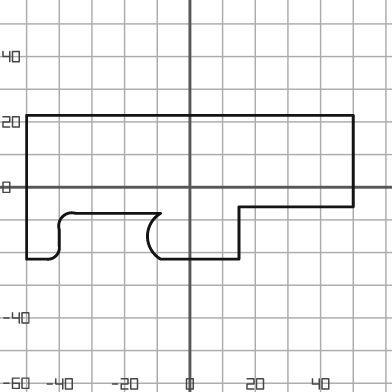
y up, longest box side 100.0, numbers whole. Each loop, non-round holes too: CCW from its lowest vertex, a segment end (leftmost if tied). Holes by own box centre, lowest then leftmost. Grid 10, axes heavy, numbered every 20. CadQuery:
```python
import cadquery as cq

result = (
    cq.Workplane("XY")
    .moveTo(-50.0, -22.0)
    .lineTo(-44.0, -22.0)
    .threePointArc((-41.0, -21.0), (-40.0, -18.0))
    .lineTo(-40.0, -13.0)
    .threePointArc((-39.0, -9.0), (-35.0, -8.0))
    .lineTo(-9.0, -8.0)
    .threePointArc((-13.0, -15.0), (-9.0, -22.0))
    .lineTo(15.0, -22.0)
    .lineTo(15.0, -6.0)
    .lineTo(50.0, -6.0)
    .lineTo(50.0, 22.0)
    .lineTo(-50.0, 22.0)
    .close()
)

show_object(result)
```